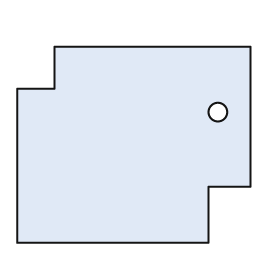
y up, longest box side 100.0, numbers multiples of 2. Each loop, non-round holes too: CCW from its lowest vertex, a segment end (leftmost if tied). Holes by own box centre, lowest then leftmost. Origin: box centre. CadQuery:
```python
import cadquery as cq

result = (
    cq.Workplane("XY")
    .moveTo(-50.0, -42.0)
    .lineTo(32.0, -42.0)
    .lineTo(32.0, -18.0)
    .lineTo(50.0, -18.0)
    .lineTo(50.0, 42.0)
    .lineTo(-34.0, 42.0)
    .lineTo(-34.0, 24.0)
    .lineTo(-50.0, 24.0)
    .close()
    .moveTo(36.0, 14.0)
    .circle(4.0)
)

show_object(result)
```